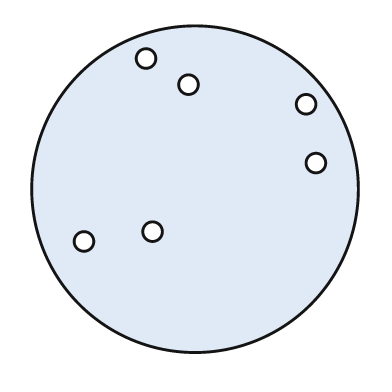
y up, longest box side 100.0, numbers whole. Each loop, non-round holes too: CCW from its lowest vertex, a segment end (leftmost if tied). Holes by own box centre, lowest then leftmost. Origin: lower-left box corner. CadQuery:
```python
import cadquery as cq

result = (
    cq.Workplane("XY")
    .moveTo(50.0, 50.0)
    .circle(50.0)
    .moveTo(16.0, 34.0)
    .circle(3.0)
    .moveTo(37.0, 37.0)
    .circle(3.0)
    .moveTo(87.0, 58.0)
    .circle(3.0)
    .moveTo(84.0, 76.0)
    .circle(3.0)
    .moveTo(48.0, 82.0)
    .circle(3.0)
    .moveTo(35.0, 90.0)
    .circle(3.0)
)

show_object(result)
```